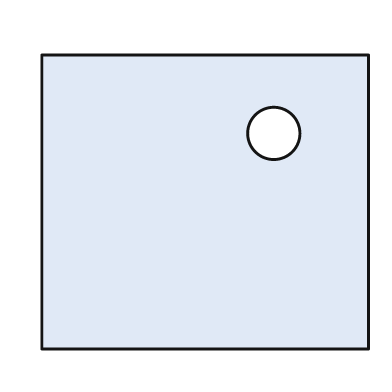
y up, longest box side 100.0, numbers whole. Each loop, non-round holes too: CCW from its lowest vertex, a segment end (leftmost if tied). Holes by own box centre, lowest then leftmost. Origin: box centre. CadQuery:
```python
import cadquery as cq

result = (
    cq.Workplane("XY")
    .moveTo(-50.0, -45.0)
    .lineTo(50.0, -45.0)
    .lineTo(50.0, 45.0)
    .lineTo(-50.0, 45.0)
    .close()
    .moveTo(21.0, 21.0)
    .circle(8.0)
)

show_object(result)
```